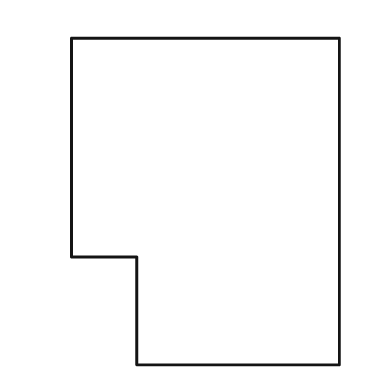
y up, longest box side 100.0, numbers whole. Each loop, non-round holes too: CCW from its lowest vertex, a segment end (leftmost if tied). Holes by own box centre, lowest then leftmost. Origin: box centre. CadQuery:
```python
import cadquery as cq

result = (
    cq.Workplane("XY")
    .moveTo(-21.0, -50.0)
    .lineTo(41.0, -50.0)
    .lineTo(41.0, 50.0)
    .lineTo(-41.0, 50.0)
    .lineTo(-41.0, -17.0)
    .lineTo(-21.0, -17.0)
    .close()
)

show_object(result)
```